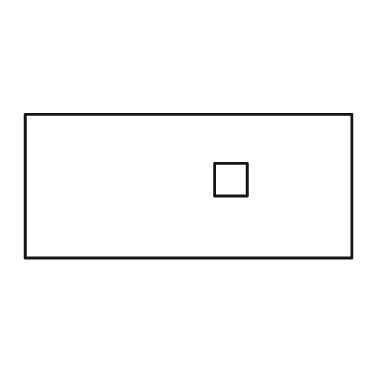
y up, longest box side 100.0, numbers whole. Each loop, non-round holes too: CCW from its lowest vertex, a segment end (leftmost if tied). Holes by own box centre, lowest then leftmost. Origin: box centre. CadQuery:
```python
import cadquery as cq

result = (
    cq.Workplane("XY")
    .moveTo(-50.0, -22.0)
    .lineTo(50.0, -22.0)
    .lineTo(50.0, 22.0)
    .lineTo(-50.0, 22.0)
    .close()
    .moveTo(8.0, -3.0)
    .lineTo(18.0, -3.0)
    .lineTo(18.0, 7.0)
    .lineTo(8.0, 7.0)
    .close()
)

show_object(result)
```